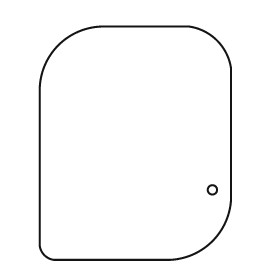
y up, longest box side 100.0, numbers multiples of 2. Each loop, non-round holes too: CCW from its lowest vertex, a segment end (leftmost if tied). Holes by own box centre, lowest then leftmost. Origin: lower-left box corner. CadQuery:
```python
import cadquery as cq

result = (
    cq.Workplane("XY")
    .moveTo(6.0, 0.0)
    .lineTo(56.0, 0.0)
    .threePointArc((74.0, 8.0), (82.0, 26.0))
    .lineTo(82.0, 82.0)
    .threePointArc((76.0, 94.0), (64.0, 100.0))
    .lineTo(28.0, 100.0)
    .threePointArc((8.0, 92.0), (0.0, 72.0))
    .lineTo(0.0, 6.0)
    .threePointArc((2.0, 2.0), (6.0, 0.0))
    .close()
    .moveTo(74.0, 30.0)
    .circle(2.0)
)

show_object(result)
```